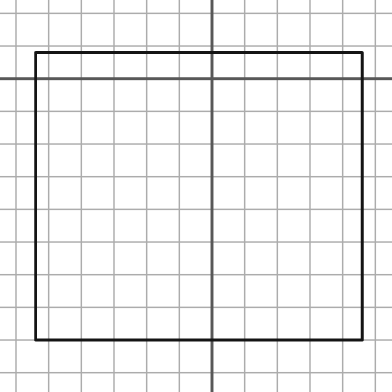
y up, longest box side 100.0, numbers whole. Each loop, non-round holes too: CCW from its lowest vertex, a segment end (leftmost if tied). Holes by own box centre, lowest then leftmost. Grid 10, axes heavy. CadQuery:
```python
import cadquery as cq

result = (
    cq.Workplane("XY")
    .moveTo(-54.0, -80.0)
    .lineTo(46.0, -80.0)
    .lineTo(46.0, 8.0)
    .lineTo(-54.0, 8.0)
    .close()
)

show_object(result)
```